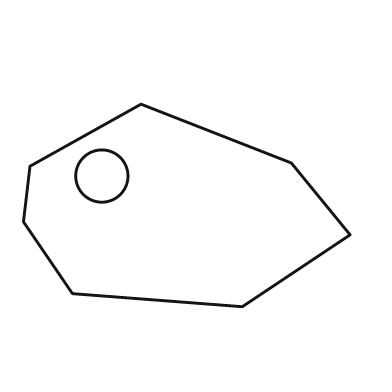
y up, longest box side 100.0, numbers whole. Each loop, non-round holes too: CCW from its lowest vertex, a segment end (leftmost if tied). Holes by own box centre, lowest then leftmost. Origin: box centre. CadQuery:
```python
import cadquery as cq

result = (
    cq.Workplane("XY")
    .moveTo(17.0, -31.0)
    .lineTo(50.0, -9.0)
    .lineTo(32.0, 13.0)
    .lineTo(-14.0, 31.0)
    .lineTo(-48.0, 12.0)
    .lineTo(-50.0, -5.0)
    .lineTo(-35.0, -27.0)
    .close()
    .moveTo(-26.0, 9.0)
    .circle(8.0)
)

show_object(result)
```